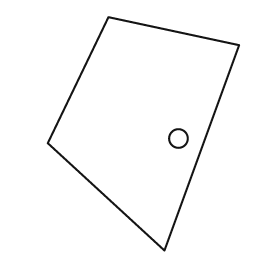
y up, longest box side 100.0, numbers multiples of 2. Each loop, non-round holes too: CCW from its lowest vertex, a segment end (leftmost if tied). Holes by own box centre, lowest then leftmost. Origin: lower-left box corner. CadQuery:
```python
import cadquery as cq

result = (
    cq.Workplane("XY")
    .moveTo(50.0, 0.0)
    .lineTo(82.0, 88.0)
    .lineTo(26.0, 100.0)
    .lineTo(0.0, 46.0)
    .close()
    .moveTo(56.0, 48.0)
    .circle(4.0)
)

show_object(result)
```